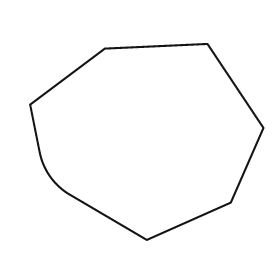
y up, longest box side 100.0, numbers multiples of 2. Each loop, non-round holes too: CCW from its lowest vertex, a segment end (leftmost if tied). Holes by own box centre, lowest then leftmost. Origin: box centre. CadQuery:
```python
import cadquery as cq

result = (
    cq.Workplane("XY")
    .moveTo(0.0, -42.0)
    .lineTo(36.0, -26.0)
    .lineTo(50.0, 6.0)
    .lineTo(26.0, 42.0)
    .lineTo(-18.0, 40.0)
    .lineTo(-50.0, 16.0)
    .lineTo(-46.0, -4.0)
    .threePointArc((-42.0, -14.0), (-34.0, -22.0))
    .close()
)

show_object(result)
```